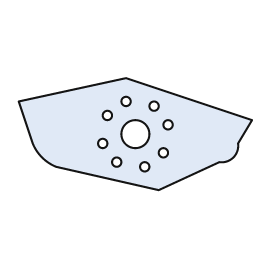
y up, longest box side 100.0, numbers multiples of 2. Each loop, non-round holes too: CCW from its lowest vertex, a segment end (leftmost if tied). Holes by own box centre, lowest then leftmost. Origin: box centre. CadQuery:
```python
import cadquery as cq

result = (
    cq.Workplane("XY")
    .moveTo(10.0, -24.0)
    .lineTo(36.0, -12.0)
    .threePointArc((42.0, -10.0), (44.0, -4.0))
    .lineTo(50.0, 6.0)
    .lineTo(-4.0, 24.0)
    .lineTo(-50.0, 14.0)
    .lineTo(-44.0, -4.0)
    .threePointArc((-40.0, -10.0), (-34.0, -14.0))
    .close()
    .moveTo(4.0, -14.0)
    .circle(2.0)
    .moveTo(-8.0, -12.0)
    .circle(2.0)
    .moveTo(12.0, -8.0)
    .circle(2.0)
    .moveTo(-14.0, -4.0)
    .circle(2.0)
    .moveTo(0.0, 0.0)
    .circle(6.0)
    .moveTo(14.0, 4.0)
    .circle(2.0)
    .moveTo(-12.0, 8.0)
    .circle(2.0)
    .moveTo(8.0, 12.0)
    .circle(2.0)
    .moveTo(-4.0, 14.0)
    .circle(2.0)
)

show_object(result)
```